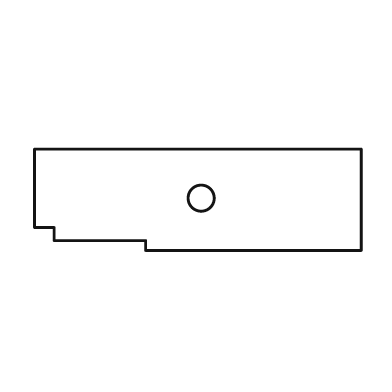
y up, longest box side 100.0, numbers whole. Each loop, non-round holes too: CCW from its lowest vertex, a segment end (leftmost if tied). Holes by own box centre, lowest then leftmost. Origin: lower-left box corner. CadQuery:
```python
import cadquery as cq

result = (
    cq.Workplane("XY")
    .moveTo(34.0, 0.0)
    .lineTo(100.0, 0.0)
    .lineTo(100.0, 31.0)
    .lineTo(0.0, 31.0)
    .lineTo(0.0, 7.0)
    .lineTo(6.0, 7.0)
    .lineTo(6.0, 3.0)
    .lineTo(34.0, 3.0)
    .close()
    .moveTo(51.0, 16.0)
    .circle(4.0)
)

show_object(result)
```